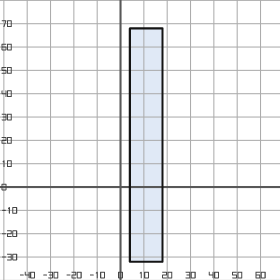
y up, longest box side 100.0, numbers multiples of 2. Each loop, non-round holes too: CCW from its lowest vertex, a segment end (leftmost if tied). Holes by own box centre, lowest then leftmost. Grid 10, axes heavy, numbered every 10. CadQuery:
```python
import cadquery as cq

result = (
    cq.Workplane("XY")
    .moveTo(4.0, -32.0)
    .lineTo(18.0, -32.0)
    .lineTo(18.0, 68.0)
    .lineTo(4.0, 68.0)
    .close()
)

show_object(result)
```